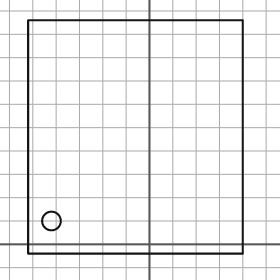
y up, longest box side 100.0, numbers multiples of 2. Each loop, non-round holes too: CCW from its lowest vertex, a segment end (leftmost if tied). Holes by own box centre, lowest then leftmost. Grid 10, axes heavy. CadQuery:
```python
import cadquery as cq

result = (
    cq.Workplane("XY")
    .moveTo(-52.0, -4.0)
    .lineTo(40.0, -4.0)
    .lineTo(40.0, 96.0)
    .lineTo(-52.0, 96.0)
    .close()
    .moveTo(-42.0, 10.0)
    .circle(4.0)
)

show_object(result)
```